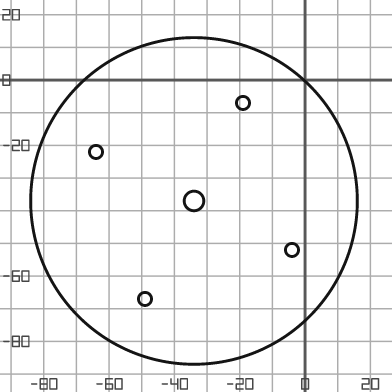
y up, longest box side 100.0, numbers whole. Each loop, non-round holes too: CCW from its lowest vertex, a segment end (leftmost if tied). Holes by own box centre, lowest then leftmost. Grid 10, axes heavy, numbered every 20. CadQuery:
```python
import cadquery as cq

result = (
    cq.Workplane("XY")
    .moveTo(-34.0, -37.0)
    .circle(50.0)
    .moveTo(-49.0, -67.0)
    .circle(2.0)
    .moveTo(-4.0, -52.0)
    .circle(2.0)
    .moveTo(-34.0, -37.0)
    .circle(3.0)
    .moveTo(-64.0, -22.0)
    .circle(2.0)
    .moveTo(-19.0, -7.0)
    .circle(2.0)
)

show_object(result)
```